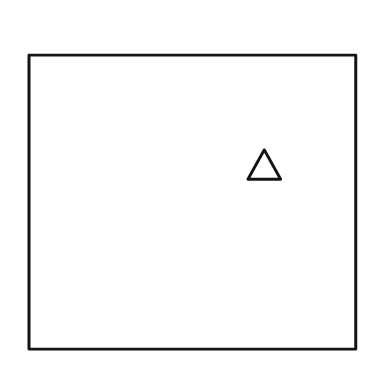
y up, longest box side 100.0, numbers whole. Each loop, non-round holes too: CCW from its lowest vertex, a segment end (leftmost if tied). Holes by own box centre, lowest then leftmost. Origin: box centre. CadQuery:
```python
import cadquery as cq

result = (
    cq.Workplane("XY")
    .moveTo(-50.0, -45.0)
    .lineTo(50.0, -45.0)
    .lineTo(50.0, 45.0)
    .lineTo(-50.0, 45.0)
    .close()
    .moveTo(17.0, 7.0)
    .lineTo(27.0, 7.0)
    .lineTo(22.0, 16.0)
    .close()
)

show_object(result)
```